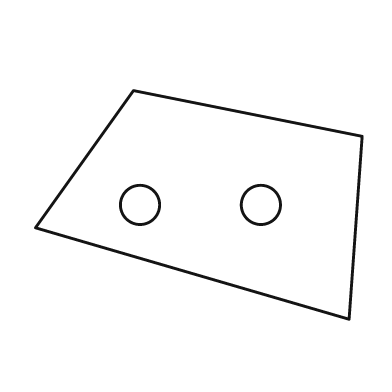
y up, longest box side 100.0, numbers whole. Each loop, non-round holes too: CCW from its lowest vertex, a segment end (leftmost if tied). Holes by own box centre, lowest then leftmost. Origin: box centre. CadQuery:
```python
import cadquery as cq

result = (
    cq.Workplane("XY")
    .moveTo(46.0, -35.0)
    .lineTo(50.0, 21.0)
    .lineTo(-20.0, 35.0)
    .lineTo(-50.0, -7.0)
    .close()
    .moveTo(-18.0, 0.0)
    .circle(6.0)
    .moveTo(19.0, 0.0)
    .circle(6.0)
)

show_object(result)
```